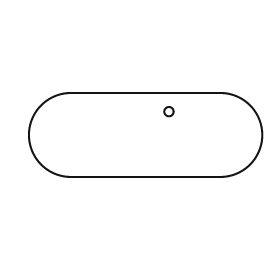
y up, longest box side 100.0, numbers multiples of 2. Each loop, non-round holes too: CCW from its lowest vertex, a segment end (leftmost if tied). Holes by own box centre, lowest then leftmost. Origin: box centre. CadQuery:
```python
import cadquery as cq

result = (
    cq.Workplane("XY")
    .moveTo(-32.0, -18.0)
    .lineTo(32.0, -18.0)
    .threePointArc((50.0, 0.0), (32.0, 18.0))
    .lineTo(-32.0, 18.0)
    .threePointArc((-50.0, 0.0), (-32.0, -18.0))
    .close()
    .moveTo(10.0, 10.0)
    .circle(2.0)
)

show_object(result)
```